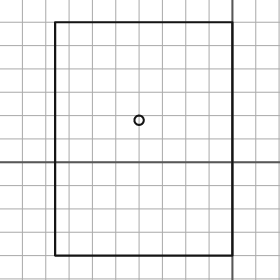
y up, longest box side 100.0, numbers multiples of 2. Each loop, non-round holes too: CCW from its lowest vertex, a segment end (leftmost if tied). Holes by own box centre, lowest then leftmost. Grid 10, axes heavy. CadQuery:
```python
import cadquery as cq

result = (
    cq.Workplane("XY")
    .moveTo(-76.0, -40.0)
    .lineTo(0.0, -40.0)
    .lineTo(0.0, 60.0)
    .lineTo(-76.0, 60.0)
    .close()
    .moveTo(-40.0, 18.0)
    .circle(2.0)
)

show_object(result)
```